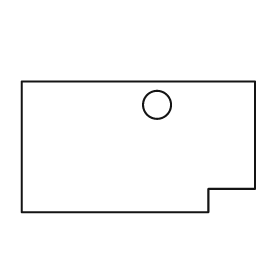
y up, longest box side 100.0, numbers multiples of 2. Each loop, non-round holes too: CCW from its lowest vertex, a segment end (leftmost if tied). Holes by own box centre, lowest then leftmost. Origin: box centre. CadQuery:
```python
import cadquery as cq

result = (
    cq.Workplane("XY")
    .moveTo(-50.0, -28.0)
    .lineTo(30.0, -28.0)
    .lineTo(30.0, -18.0)
    .lineTo(50.0, -18.0)
    .lineTo(50.0, 28.0)
    .lineTo(-50.0, 28.0)
    .close()
    .moveTo(8.0, 18.0)
    .circle(6.0)
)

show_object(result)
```